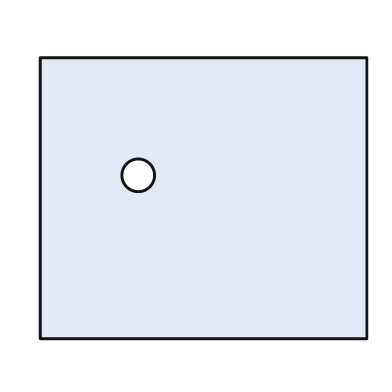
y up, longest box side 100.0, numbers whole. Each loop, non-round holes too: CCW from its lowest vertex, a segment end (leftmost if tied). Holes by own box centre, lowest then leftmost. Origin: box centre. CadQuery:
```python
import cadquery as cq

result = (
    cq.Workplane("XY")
    .moveTo(-50.0, -43.0)
    .lineTo(50.0, -43.0)
    .lineTo(50.0, 43.0)
    .lineTo(-50.0, 43.0)
    .close()
    .moveTo(-20.0, 7.0)
    .circle(5.0)
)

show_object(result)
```